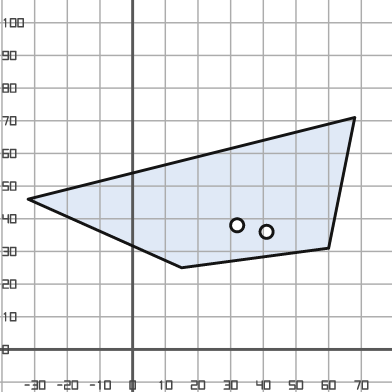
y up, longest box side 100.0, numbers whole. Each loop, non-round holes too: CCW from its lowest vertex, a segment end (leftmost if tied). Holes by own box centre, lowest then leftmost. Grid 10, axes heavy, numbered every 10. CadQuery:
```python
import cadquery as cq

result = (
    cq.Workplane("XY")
    .moveTo(15.0, 25.0)
    .lineTo(60.0, 31.0)
    .lineTo(68.0, 71.0)
    .lineTo(-32.0, 46.0)
    .close()
    .moveTo(41.0, 36.0)
    .circle(2.0)
    .moveTo(32.0, 38.0)
    .circle(2.0)
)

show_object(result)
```